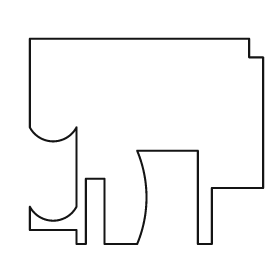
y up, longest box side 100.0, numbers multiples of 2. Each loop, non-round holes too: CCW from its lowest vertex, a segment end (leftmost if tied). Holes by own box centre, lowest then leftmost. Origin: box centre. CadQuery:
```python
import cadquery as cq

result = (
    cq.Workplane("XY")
    .moveTo(-30.0, -44.0)
    .lineTo(-26.0, -44.0)
    .lineTo(-26.0, -16.0)
    .lineTo(-18.0, -16.0)
    .lineTo(-18.0, -44.0)
    .lineTo(-4.0, -44.0)
    .threePointArc((0.0, -24.0), (-4.0, -4.0))
    .lineTo(22.0, -4.0)
    .lineTo(22.0, -44.0)
    .lineTo(28.0, -44.0)
    .lineTo(28.0, -20.0)
    .lineTo(50.0, -20.0)
    .lineTo(50.0, 36.0)
    .lineTo(44.0, 36.0)
    .lineTo(44.0, 44.0)
    .lineTo(-50.0, 44.0)
    .lineTo(-50.0, 6.0)
    .threePointArc((-40.0, 0.0), (-30.0, 6.0))
    .lineTo(-30.0, -28.0)
    .threePointArc((-40.0, -34.0), (-50.0, -28.0))
    .lineTo(-50.0, -38.0)
    .lineTo(-30.0, -38.0)
    .close()
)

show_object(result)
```